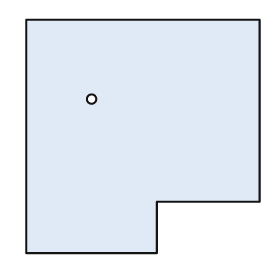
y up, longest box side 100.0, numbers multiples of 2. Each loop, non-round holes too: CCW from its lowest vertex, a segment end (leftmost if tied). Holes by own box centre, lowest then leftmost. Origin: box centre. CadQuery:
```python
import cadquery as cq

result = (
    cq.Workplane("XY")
    .moveTo(-50.0, -50.0)
    .lineTo(6.0, -50.0)
    .lineTo(6.0, -28.0)
    .lineTo(50.0, -28.0)
    .lineTo(50.0, 50.0)
    .lineTo(-50.0, 50.0)
    .close()
    .moveTo(-22.0, 16.0)
    .circle(2.0)
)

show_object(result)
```